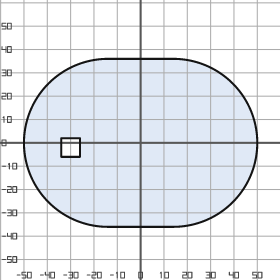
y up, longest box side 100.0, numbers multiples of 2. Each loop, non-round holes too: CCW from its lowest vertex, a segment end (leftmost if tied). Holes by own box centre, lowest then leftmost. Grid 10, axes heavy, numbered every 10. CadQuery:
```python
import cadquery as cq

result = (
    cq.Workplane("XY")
    .moveTo(-14.0, -36.0)
    .lineTo(14.0, -36.0)
    .threePointArc((50.0, 0.0), (14.0, 36.0))
    .lineTo(-14.0, 36.0)
    .threePointArc((-50.0, 0.0), (-14.0, -36.0))
    .close()
    .moveTo(-34.0, -6.0)
    .lineTo(-26.0, -6.0)
    .lineTo(-26.0, 2.0)
    .lineTo(-34.0, 2.0)
    .close()
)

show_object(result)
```